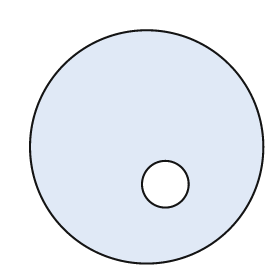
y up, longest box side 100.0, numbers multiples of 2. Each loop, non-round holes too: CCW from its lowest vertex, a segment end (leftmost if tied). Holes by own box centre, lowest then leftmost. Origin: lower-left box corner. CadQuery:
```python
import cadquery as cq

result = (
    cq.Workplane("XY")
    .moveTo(50.0, 50.0)
    .circle(50.0)
    .moveTo(58.0, 34.0)
    .circle(10.0)
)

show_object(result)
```